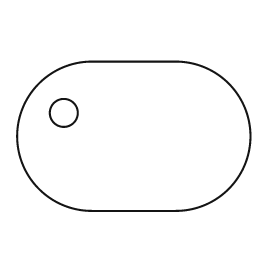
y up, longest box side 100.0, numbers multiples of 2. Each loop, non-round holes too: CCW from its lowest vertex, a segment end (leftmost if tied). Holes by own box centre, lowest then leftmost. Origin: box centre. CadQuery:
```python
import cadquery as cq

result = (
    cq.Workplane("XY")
    .moveTo(-18.0, -32.0)
    .lineTo(18.0, -32.0)
    .threePointArc((50.0, 0.0), (18.0, 32.0))
    .lineTo(-18.0, 32.0)
    .threePointArc((-50.0, 0.0), (-18.0, -32.0))
    .close()
    .moveTo(-30.0, 10.0)
    .circle(6.0)
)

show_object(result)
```